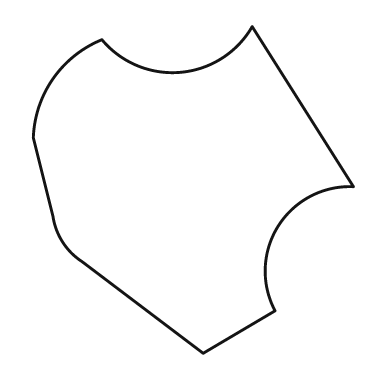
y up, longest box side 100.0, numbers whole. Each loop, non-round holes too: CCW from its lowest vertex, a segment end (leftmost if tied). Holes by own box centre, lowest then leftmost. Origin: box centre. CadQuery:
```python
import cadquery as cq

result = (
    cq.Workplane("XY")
    .moveTo(3.0, -50.0)
    .lineTo(25.0, -37.0)
    .threePointArc((26.0, -11.0), (49.0, 1.0))
    .lineTo(18.0, 50.0)
    .threePointArc((-4.0, 36.0), (-28.0, 46.0))
    .threePointArc((-43.0, 34.0), (-49.0, 16.0))
    .lineTo(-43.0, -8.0)
    .threePointArc((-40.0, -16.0), (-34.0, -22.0))
    .close()
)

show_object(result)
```